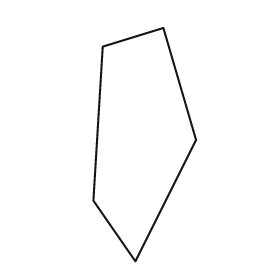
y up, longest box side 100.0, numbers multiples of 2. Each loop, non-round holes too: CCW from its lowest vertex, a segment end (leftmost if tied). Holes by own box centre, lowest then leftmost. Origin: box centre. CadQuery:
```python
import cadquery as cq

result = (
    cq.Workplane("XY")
    .moveTo(-4.0, -50.0)
    .lineTo(22.0, 2.0)
    .lineTo(8.0, 50.0)
    .lineTo(-18.0, 42.0)
    .lineTo(-22.0, -24.0)
    .close()
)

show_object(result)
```